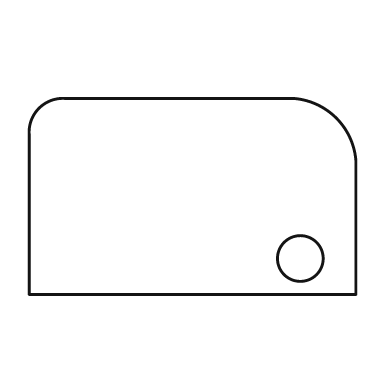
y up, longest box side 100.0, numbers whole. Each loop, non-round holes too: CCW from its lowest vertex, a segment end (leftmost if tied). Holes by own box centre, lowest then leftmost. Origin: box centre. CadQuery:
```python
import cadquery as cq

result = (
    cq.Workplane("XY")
    .moveTo(-50.0, -30.0)
    .lineTo(50.0, -30.0)
    .lineTo(50.0, 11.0)
    .threePointArc((44.0, 24.0), (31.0, 30.0))
    .lineTo(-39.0, 30.0)
    .threePointArc((-47.0, 27.0), (-50.0, 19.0))
    .close()
    .moveTo(33.0, -19.0)
    .circle(7.0)
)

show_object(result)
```